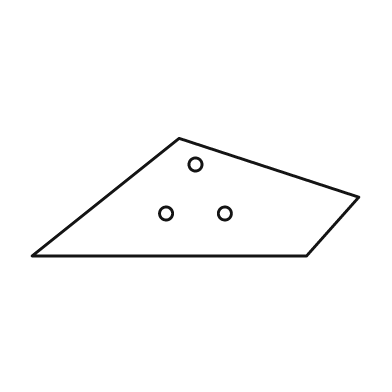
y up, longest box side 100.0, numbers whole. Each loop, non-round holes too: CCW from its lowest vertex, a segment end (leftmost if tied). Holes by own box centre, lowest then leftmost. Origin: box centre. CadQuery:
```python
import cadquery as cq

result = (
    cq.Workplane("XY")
    .moveTo(-50.0, -18.0)
    .lineTo(34.0, -18.0)
    .lineTo(50.0, 0.0)
    .lineTo(-5.0, 18.0)
    .close()
    .moveTo(-9.0, -5.0)
    .circle(2.0)
    .moveTo(9.0, -5.0)
    .circle(2.0)
    .moveTo(0.0, 10.0)
    .circle(2.0)
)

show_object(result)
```